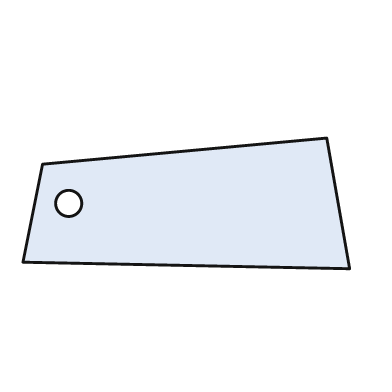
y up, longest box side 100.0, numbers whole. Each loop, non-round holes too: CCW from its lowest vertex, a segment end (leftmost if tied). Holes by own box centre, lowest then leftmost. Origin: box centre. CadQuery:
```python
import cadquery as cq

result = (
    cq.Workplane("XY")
    .moveTo(50.0, -20.0)
    .lineTo(43.0, 20.0)
    .lineTo(-44.0, 12.0)
    .lineTo(-50.0, -18.0)
    .close()
    .moveTo(-36.0, 0.0)
    .circle(4.0)
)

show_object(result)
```